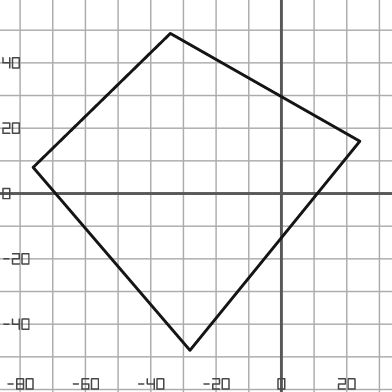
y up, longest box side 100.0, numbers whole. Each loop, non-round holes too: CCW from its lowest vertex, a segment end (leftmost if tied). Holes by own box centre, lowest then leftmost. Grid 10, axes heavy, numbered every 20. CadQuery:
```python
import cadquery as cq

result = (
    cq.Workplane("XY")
    .moveTo(-28.0, -48.0)
    .lineTo(24.0, 16.0)
    .lineTo(-34.0, 49.0)
    .lineTo(-76.0, 8.0)
    .close()
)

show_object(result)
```